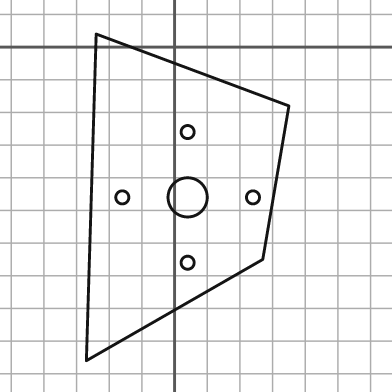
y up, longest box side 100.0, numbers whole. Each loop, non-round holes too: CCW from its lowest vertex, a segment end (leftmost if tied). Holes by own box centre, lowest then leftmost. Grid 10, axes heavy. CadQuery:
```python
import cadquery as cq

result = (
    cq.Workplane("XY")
    .moveTo(-27.0, -96.0)
    .lineTo(27.0, -65.0)
    .lineTo(35.0, -18.0)
    .lineTo(-24.0, 4.0)
    .close()
    .moveTo(4.0, -66.0)
    .circle(2.0)
    .moveTo(-16.0, -46.0)
    .circle(2.0)
    .moveTo(4.0, -46.0)
    .circle(6.0)
    .moveTo(24.0, -46.0)
    .circle(2.0)
    .moveTo(4.0, -26.0)
    .circle(2.0)
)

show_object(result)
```